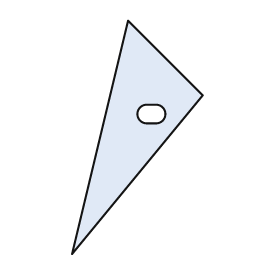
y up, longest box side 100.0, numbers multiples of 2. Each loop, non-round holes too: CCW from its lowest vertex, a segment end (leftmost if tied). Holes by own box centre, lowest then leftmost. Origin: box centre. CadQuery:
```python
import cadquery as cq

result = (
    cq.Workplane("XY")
    .moveTo(-28.0, -50.0)
    .lineTo(28.0, 18.0)
    .lineTo(-4.0, 50.0)
    .close()
    .moveTo(4.0, 6.0)
    .lineTo(8.0, 6.0)
    .threePointArc((12.0, 10.0), (8.0, 14.0))
    .lineTo(4.0, 14.0)
    .threePointArc((0.0, 10.0), (4.0, 6.0))
    .close()
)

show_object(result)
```